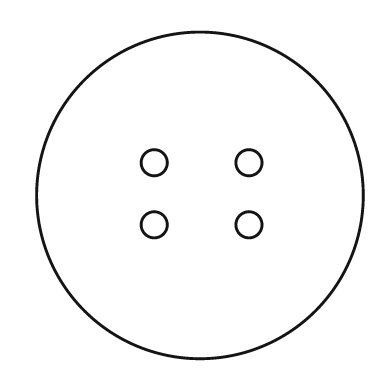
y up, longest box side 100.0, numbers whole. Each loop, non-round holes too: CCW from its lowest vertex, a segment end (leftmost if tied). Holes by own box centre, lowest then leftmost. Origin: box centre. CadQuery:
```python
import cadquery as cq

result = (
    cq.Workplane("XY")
    .moveTo(0.0, 0.0)
    .circle(50.0)
    .moveTo(-14.0, -9.0)
    .circle(4.0)
    .moveTo(15.0, -9.0)
    .circle(4.0)
    .moveTo(-14.0, 10.0)
    .circle(4.0)
    .moveTo(15.0, 10.0)
    .circle(4.0)
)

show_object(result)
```